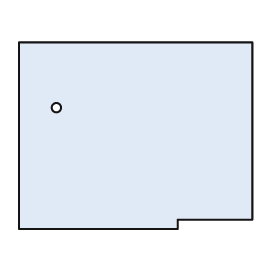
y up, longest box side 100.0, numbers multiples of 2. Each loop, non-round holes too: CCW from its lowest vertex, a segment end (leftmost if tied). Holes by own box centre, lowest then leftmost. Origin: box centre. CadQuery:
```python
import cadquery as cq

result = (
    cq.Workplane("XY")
    .moveTo(-50.0, -40.0)
    .lineTo(18.0, -40.0)
    .lineTo(18.0, -36.0)
    .lineTo(50.0, -36.0)
    .lineTo(50.0, 40.0)
    .lineTo(-50.0, 40.0)
    .close()
    .moveTo(-34.0, 12.0)
    .circle(2.0)
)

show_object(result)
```